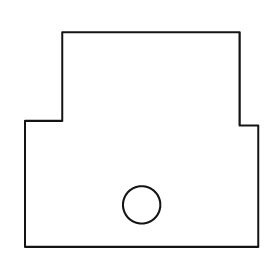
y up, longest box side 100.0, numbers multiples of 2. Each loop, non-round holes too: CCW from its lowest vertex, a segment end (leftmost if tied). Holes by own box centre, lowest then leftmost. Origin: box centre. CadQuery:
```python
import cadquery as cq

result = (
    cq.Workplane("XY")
    .moveTo(-50.0, -46.0)
    .lineTo(50.0, -46.0)
    .lineTo(50.0, 6.0)
    .lineTo(42.0, 6.0)
    .lineTo(42.0, 46.0)
    .lineTo(-34.0, 46.0)
    .lineTo(-34.0, 8.0)
    .lineTo(-50.0, 8.0)
    .close()
    .moveTo(0.0, -28.0)
    .circle(8.0)
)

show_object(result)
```